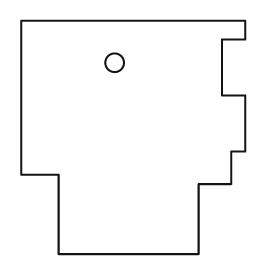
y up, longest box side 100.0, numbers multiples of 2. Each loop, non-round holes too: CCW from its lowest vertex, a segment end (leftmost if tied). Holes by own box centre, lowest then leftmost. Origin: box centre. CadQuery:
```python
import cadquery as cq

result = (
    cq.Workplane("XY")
    .moveTo(-32.0, -50.0)
    .lineTo(28.0, -50.0)
    .lineTo(28.0, -20.0)
    .lineTo(42.0, -20.0)
    .lineTo(42.0, -6.0)
    .lineTo(48.0, -6.0)
    .lineTo(48.0, 18.0)
    .lineTo(38.0, 18.0)
    .lineTo(38.0, 42.0)
    .lineTo(48.0, 42.0)
    .lineTo(48.0, 50.0)
    .lineTo(-48.0, 50.0)
    .lineTo(-48.0, -16.0)
    .lineTo(-32.0, -16.0)
    .close()
    .moveTo(-8.0, 32.0)
    .circle(4.0)
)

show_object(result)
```